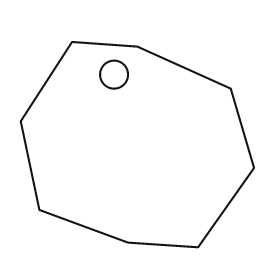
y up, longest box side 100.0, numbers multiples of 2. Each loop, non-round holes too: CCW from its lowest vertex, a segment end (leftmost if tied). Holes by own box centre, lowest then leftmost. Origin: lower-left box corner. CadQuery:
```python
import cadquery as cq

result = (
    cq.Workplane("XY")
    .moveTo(76.0, 0.0)
    .lineTo(100.0, 34.0)
    .lineTo(90.0, 68.0)
    .lineTo(50.0, 86.0)
    .lineTo(22.0, 88.0)
    .lineTo(0.0, 54.0)
    .lineTo(8.0, 16.0)
    .lineTo(46.0, 2.0)
    .close()
    .moveTo(40.0, 74.0)
    .circle(6.0)
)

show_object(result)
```